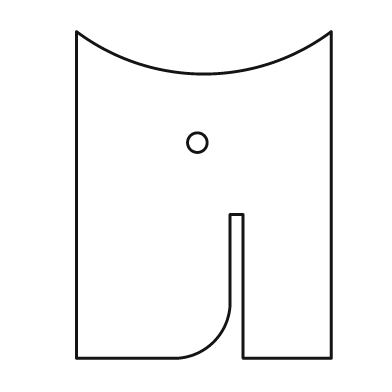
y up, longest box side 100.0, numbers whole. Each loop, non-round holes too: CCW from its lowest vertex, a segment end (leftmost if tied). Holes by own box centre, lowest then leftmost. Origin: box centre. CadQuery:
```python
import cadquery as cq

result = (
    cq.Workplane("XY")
    .moveTo(-39.0, -50.0)
    .lineTo(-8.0, -50.0)
    .threePointArc((3.0, -45.0), (8.0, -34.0))
    .lineTo(8.0, -6.0)
    .lineTo(12.0, -6.0)
    .lineTo(12.0, -50.0)
    .lineTo(39.0, -50.0)
    .lineTo(39.0, 50.0)
    .threePointArc((0.0, 37.0), (-39.0, 50.0))
    .close()
    .moveTo(-2.0, 16.0)
    .circle(3.0)
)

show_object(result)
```